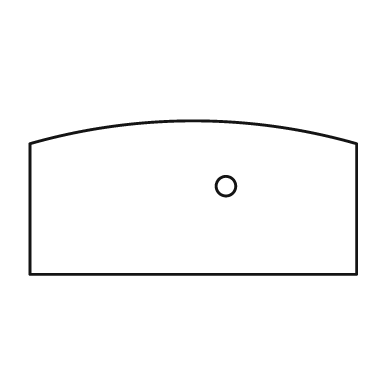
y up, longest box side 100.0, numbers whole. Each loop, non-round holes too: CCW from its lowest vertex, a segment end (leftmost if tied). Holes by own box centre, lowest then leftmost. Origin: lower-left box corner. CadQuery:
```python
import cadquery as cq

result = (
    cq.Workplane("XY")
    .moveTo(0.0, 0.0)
    .lineTo(100.0, 0.0)
    .lineTo(100.0, 40.0)
    .threePointArc((50.0, 47.0), (0.0, 40.0))
    .close()
    .moveTo(60.0, 27.0)
    .circle(3.0)
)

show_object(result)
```